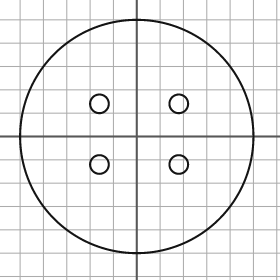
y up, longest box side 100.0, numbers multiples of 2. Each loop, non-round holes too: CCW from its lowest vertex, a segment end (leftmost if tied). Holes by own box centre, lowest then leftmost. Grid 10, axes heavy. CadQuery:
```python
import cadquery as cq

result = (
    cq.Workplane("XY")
    .moveTo(0.0, 0.0)
    .circle(50.0)
    .moveTo(-16.0, -12.0)
    .circle(4.0)
    .moveTo(18.0, -12.0)
    .circle(4.0)
    .moveTo(-16.0, 14.0)
    .circle(4.0)
    .moveTo(18.0, 14.0)
    .circle(4.0)
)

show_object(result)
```